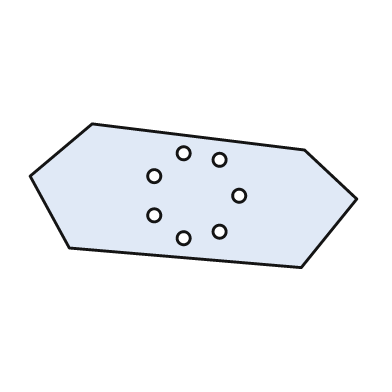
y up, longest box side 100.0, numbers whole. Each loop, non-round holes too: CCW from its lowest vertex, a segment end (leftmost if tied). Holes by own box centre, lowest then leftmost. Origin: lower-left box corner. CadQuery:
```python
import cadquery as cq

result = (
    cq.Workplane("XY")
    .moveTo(83.0, 0.0)
    .lineTo(100.0, 21.0)
    .lineTo(84.0, 36.0)
    .lineTo(19.0, 44.0)
    .lineTo(0.0, 28.0)
    .lineTo(12.0, 6.0)
    .close()
    .moveTo(47.0, 9.0)
    .circle(2.0)
    .moveTo(58.0, 11.0)
    .circle(2.0)
    .moveTo(38.0, 16.0)
    .circle(2.0)
    .moveTo(64.0, 22.0)
    .circle(2.0)
    .moveTo(38.0, 28.0)
    .circle(2.0)
    .moveTo(58.0, 33.0)
    .circle(2.0)
    .moveTo(47.0, 35.0)
    .circle(2.0)
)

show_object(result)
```